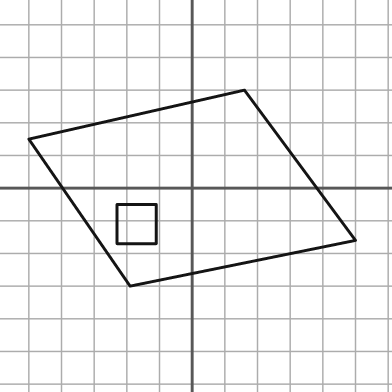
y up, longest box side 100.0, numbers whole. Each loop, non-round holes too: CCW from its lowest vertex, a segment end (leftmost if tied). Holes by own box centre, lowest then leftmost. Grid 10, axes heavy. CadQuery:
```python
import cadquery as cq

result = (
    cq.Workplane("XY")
    .moveTo(-19.0, -30.0)
    .lineTo(50.0, -16.0)
    .lineTo(16.0, 30.0)
    .lineTo(-50.0, 15.0)
    .close()
    .moveTo(-23.0, -17.0)
    .lineTo(-11.0, -17.0)
    .lineTo(-11.0, -5.0)
    .lineTo(-23.0, -5.0)
    .close()
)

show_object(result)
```